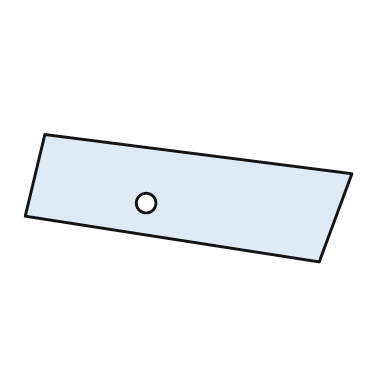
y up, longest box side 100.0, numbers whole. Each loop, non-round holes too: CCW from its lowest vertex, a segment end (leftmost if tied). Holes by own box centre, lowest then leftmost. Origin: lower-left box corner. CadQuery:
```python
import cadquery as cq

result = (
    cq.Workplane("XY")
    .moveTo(90.0, 0.0)
    .lineTo(100.0, 27.0)
    .lineTo(6.0, 39.0)
    .lineTo(0.0, 14.0)
    .close()
    .moveTo(37.0, 18.0)
    .circle(3.0)
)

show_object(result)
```